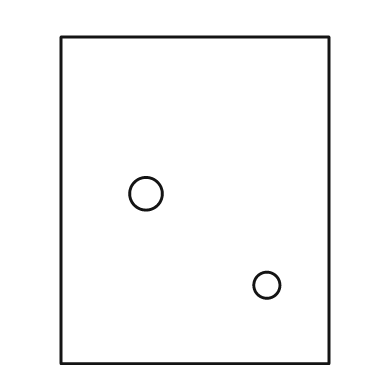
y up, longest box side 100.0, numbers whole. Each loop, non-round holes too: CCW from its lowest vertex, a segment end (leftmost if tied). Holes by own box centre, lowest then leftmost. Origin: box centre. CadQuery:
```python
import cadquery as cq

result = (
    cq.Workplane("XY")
    .moveTo(-41.0, -50.0)
    .lineTo(41.0, -50.0)
    .lineTo(41.0, 50.0)
    .lineTo(-41.0, 50.0)
    .close()
    .moveTo(22.0, -26.0)
    .circle(4.0)
    .moveTo(-15.0, 2.0)
    .circle(5.0)
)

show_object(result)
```